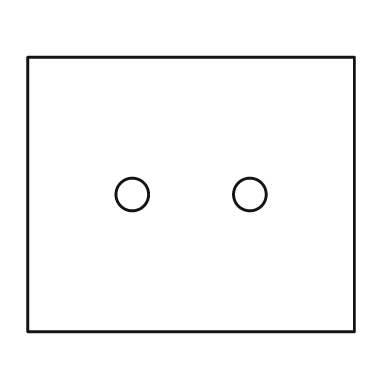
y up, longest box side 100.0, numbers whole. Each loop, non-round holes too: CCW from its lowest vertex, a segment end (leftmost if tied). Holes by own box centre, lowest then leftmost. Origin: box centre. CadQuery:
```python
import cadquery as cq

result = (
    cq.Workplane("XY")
    .moveTo(-50.0, -42.0)
    .lineTo(50.0, -42.0)
    .lineTo(50.0, 42.0)
    .lineTo(-50.0, 42.0)
    .close()
    .moveTo(-18.0, 0.0)
    .circle(5.0)
    .moveTo(18.0, 0.0)
    .circle(5.0)
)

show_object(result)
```